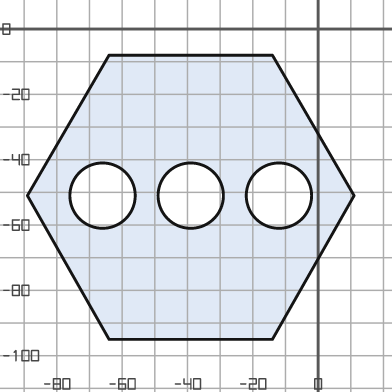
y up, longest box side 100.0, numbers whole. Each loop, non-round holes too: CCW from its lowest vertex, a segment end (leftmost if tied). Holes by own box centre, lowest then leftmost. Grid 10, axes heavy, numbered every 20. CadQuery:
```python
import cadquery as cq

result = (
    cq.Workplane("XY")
    .moveTo(-64.0, -95.0)
    .lineTo(-14.0, -95.0)
    .lineTo(11.0, -51.0)
    .lineTo(-14.0, -8.0)
    .lineTo(-64.0, -8.0)
    .lineTo(-89.0, -51.0)
    .close()
    .moveTo(-66.0, -51.0)
    .circle(10.0)
    .moveTo(-39.0, -51.0)
    .circle(10.0)
    .moveTo(-12.0, -51.0)
    .circle(10.0)
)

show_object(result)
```